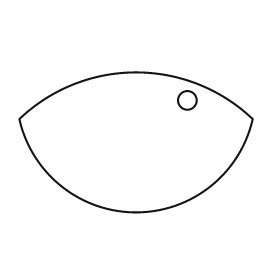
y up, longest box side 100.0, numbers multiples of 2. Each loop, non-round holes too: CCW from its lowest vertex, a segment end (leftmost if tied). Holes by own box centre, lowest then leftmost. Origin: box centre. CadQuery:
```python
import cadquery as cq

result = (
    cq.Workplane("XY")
    .moveTo(-50.0, 10.0)
    .threePointArc((0.0, -30.0), (50.0, 10.0))
    .threePointArc((0.0, 30.0), (-50.0, 10.0))
    .close()
    .moveTo(22.0, 18.0)
    .circle(4.0)
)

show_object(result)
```